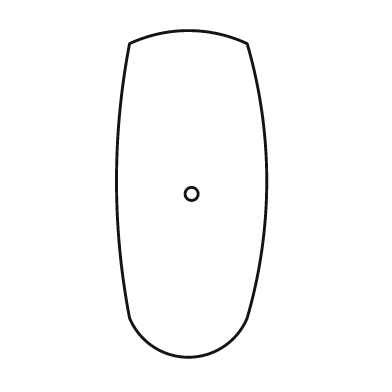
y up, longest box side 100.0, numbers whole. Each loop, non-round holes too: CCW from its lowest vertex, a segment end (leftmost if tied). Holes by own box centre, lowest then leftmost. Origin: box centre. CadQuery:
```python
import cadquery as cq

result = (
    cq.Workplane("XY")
    .moveTo(-19.0, -38.0)
    .threePointArc((-1.0, -50.0), (17.0, -38.0))
    .threePointArc((23.0, 4.0), (17.0, 46.0))
    .threePointArc((-1.0, 50.0), (-19.0, 46.0))
    .threePointArc((-23.0, 4.0), (-19.0, -38.0))
    .close()
    .moveTo(0.0, 0.0)
    .circle(2.0)
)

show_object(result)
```